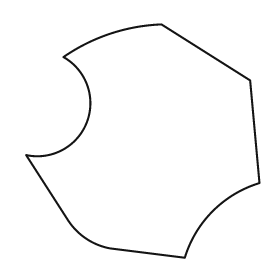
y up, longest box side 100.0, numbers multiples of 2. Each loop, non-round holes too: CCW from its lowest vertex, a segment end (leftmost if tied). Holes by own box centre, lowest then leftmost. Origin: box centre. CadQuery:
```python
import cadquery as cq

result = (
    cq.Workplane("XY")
    .moveTo(18.0, -50.0)
    .threePointArc((30.0, -30.0), (50.0, -18.0))
    .lineTo(46.0, 26.0)
    .lineTo(8.0, 50.0)
    .threePointArc((-14.0, 46.0), (-34.0, 36.0))
    .threePointArc((-24.0, 8.0), (-50.0, -6.0))
    .lineTo(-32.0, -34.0)
    .threePointArc((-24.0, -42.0), (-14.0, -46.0))
    .close()
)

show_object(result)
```